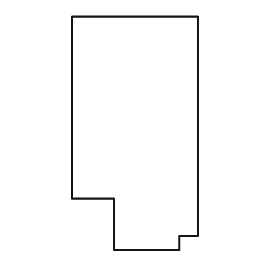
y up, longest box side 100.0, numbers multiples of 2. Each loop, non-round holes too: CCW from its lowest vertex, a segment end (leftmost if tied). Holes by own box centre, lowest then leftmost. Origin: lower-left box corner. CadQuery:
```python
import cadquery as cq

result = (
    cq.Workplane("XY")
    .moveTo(18.0, 0.0)
    .lineTo(46.0, 0.0)
    .lineTo(46.0, 6.0)
    .lineTo(54.0, 6.0)
    .lineTo(54.0, 100.0)
    .lineTo(0.0, 100.0)
    .lineTo(0.0, 22.0)
    .lineTo(18.0, 22.0)
    .close()
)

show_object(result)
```